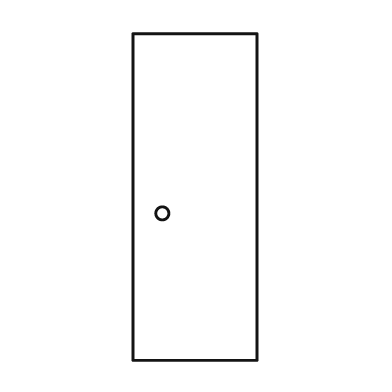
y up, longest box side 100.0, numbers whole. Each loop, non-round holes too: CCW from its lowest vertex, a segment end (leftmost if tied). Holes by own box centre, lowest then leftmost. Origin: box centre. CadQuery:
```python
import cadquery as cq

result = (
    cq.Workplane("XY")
    .moveTo(-19.0, -50.0)
    .lineTo(19.0, -50.0)
    .lineTo(19.0, 50.0)
    .lineTo(-19.0, 50.0)
    .close()
    .moveTo(-10.0, -5.0)
    .circle(2.0)
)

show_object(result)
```